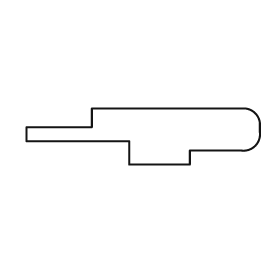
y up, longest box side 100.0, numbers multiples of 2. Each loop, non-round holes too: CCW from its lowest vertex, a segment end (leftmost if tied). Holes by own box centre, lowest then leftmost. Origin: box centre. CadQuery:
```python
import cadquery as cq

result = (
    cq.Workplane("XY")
    .moveTo(-6.0, -12.0)
    .lineTo(20.0, -12.0)
    .lineTo(20.0, -6.0)
    .lineTo(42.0, -6.0)
    .threePointArc((48.0, -4.0), (50.0, 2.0))
    .lineTo(50.0, 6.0)
    .threePointArc((48.0, 10.0), (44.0, 12.0))
    .lineTo(-22.0, 12.0)
    .lineTo(-22.0, 4.0)
    .lineTo(-50.0, 4.0)
    .lineTo(-50.0, -2.0)
    .lineTo(-6.0, -2.0)
    .close()
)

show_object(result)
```